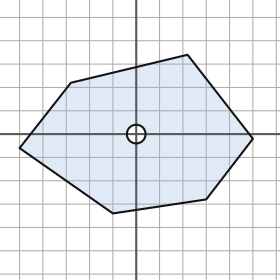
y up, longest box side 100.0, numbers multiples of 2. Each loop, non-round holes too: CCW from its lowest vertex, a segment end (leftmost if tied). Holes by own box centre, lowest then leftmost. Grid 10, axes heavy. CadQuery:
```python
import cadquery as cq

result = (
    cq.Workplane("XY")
    .moveTo(-10.0, -34.0)
    .lineTo(30.0, -28.0)
    .lineTo(50.0, -2.0)
    .lineTo(22.0, 34.0)
    .lineTo(-28.0, 22.0)
    .lineTo(-50.0, -6.0)
    .close()
    .moveTo(0.0, 0.0)
    .circle(4.0)
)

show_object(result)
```